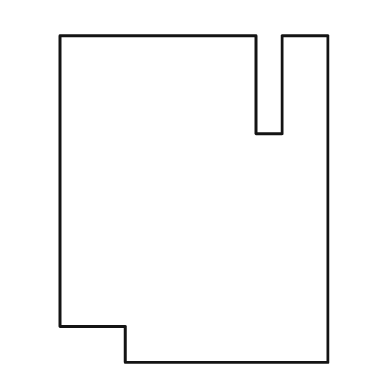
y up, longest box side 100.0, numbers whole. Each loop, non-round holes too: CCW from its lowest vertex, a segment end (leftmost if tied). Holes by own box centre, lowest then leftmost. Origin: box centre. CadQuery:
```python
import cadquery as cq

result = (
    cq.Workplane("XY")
    .moveTo(-21.0, -50.0)
    .lineTo(41.0, -50.0)
    .lineTo(41.0, 50.0)
    .lineTo(27.0, 50.0)
    .lineTo(27.0, 20.0)
    .lineTo(19.0, 20.0)
    .lineTo(19.0, 50.0)
    .lineTo(-41.0, 50.0)
    .lineTo(-41.0, -39.0)
    .lineTo(-21.0, -39.0)
    .close()
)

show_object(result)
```